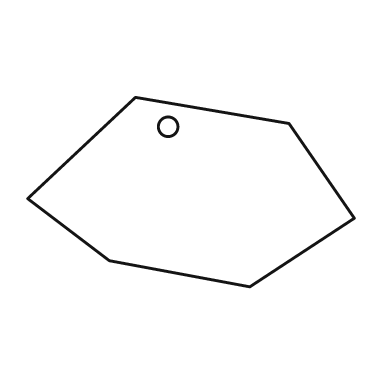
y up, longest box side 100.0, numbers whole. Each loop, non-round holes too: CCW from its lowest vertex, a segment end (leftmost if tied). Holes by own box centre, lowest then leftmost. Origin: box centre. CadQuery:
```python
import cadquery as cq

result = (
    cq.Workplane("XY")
    .moveTo(18.0, -29.0)
    .lineTo(50.0, -8.0)
    .lineTo(30.0, 21.0)
    .lineTo(-17.0, 29.0)
    .lineTo(-50.0, -2.0)
    .lineTo(-25.0, -21.0)
    .close()
    .moveTo(-7.0, 20.0)
    .circle(3.0)
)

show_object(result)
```